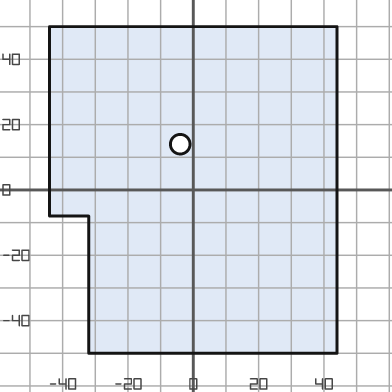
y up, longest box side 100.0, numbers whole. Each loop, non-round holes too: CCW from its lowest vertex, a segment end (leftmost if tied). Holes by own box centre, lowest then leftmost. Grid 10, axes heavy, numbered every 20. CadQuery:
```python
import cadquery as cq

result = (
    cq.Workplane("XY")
    .moveTo(-32.0, -50.0)
    .lineTo(44.0, -50.0)
    .lineTo(44.0, 50.0)
    .lineTo(-44.0, 50.0)
    .lineTo(-44.0, -8.0)
    .lineTo(-32.0, -8.0)
    .close()
    .moveTo(-4.0, 14.0)
    .circle(3.0)
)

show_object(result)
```